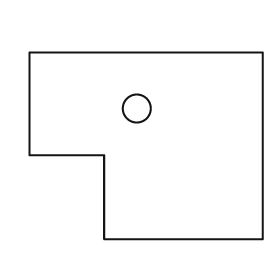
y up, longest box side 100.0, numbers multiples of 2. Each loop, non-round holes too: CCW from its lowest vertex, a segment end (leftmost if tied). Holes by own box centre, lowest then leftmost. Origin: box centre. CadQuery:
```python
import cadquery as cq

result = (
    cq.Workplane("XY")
    .moveTo(-18.0, -40.0)
    .lineTo(50.0, -40.0)
    .lineTo(50.0, 40.0)
    .lineTo(-50.0, 40.0)
    .lineTo(-50.0, -4.0)
    .lineTo(-18.0, -4.0)
    .close()
    .moveTo(-4.0, 16.0)
    .circle(6.0)
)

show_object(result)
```